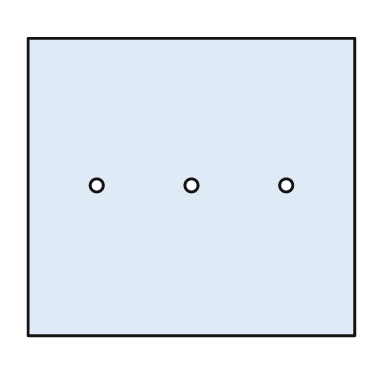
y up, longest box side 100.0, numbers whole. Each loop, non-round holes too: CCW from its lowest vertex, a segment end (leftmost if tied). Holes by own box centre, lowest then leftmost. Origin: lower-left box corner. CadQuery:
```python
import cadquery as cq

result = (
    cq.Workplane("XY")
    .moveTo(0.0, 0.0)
    .lineTo(100.0, 0.0)
    .lineTo(100.0, 91.0)
    .lineTo(0.0, 91.0)
    .close()
    .moveTo(21.0, 46.0)
    .circle(2.0)
    .moveTo(50.0, 46.0)
    .circle(2.0)
    .moveTo(79.0, 46.0)
    .circle(2.0)
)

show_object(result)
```